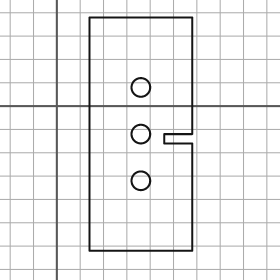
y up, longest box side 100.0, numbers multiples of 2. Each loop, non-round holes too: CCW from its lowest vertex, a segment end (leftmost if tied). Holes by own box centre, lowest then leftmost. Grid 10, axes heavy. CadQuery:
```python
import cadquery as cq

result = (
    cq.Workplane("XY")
    .moveTo(14.0, -62.0)
    .lineTo(58.0, -62.0)
    .lineTo(58.0, -16.0)
    .lineTo(46.0, -16.0)
    .lineTo(46.0, -12.0)
    .lineTo(58.0, -12.0)
    .lineTo(58.0, 38.0)
    .lineTo(14.0, 38.0)
    .close()
    .moveTo(36.0, -32.0)
    .circle(4.0)
    .moveTo(36.0, -12.0)
    .circle(4.0)
    .moveTo(36.0, 8.0)
    .circle(4.0)
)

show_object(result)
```